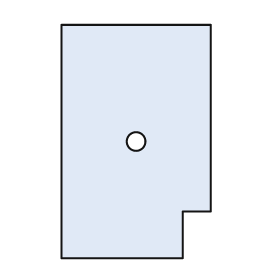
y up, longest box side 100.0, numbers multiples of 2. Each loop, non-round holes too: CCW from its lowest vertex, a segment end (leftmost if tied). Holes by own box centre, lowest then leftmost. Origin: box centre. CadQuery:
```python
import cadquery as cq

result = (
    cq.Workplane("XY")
    .moveTo(-32.0, -50.0)
    .lineTo(20.0, -50.0)
    .lineTo(20.0, -30.0)
    .lineTo(32.0, -30.0)
    .lineTo(32.0, 50.0)
    .lineTo(-32.0, 50.0)
    .close()
    .moveTo(0.0, 0.0)
    .circle(4.0)
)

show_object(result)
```